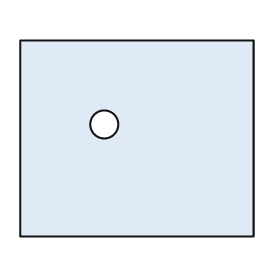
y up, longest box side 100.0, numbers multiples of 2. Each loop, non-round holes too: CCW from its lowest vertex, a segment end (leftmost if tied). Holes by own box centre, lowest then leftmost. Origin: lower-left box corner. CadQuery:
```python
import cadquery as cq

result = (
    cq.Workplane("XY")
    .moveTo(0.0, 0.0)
    .lineTo(100.0, 0.0)
    .lineTo(100.0, 84.0)
    .lineTo(0.0, 84.0)
    .close()
    .moveTo(36.0, 48.0)
    .circle(6.0)
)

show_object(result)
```